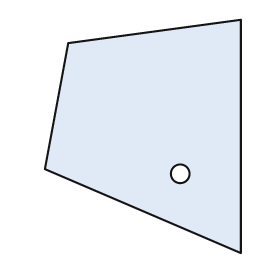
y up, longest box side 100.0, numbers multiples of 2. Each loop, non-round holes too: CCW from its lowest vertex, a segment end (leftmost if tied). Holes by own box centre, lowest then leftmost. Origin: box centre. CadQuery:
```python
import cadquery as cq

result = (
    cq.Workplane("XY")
    .moveTo(42.0, -50.0)
    .lineTo(42.0, 50.0)
    .lineTo(-32.0, 40.0)
    .lineTo(-42.0, -14.0)
    .close()
    .moveTo(16.0, -16.0)
    .circle(4.0)
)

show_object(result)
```